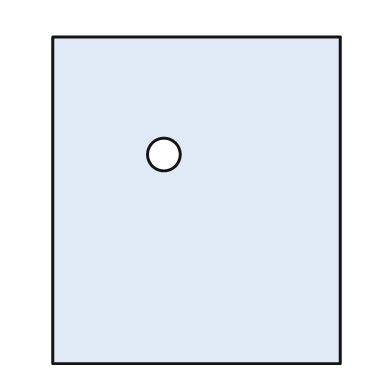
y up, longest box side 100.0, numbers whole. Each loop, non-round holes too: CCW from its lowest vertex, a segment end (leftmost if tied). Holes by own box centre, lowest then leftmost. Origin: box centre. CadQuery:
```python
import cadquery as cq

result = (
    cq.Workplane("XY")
    .moveTo(-44.0, -50.0)
    .lineTo(44.0, -50.0)
    .lineTo(44.0, 50.0)
    .lineTo(-44.0, 50.0)
    .close()
    .moveTo(-10.0, 14.0)
    .circle(5.0)
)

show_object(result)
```